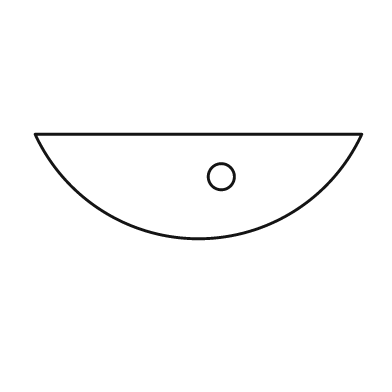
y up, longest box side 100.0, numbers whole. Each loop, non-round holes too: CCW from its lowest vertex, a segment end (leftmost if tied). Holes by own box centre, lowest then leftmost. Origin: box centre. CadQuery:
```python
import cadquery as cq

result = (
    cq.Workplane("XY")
    .moveTo(-50.0, 16.0)
    .threePointArc((0.0, -16.0), (50.0, 16.0))
    .close()
    .moveTo(7.0, 3.0)
    .circle(4.0)
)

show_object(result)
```